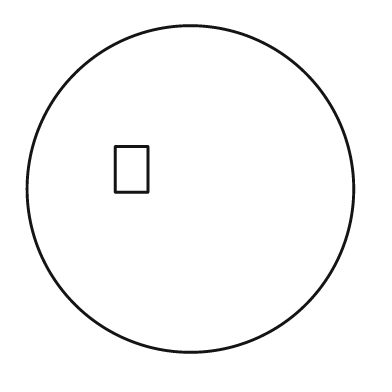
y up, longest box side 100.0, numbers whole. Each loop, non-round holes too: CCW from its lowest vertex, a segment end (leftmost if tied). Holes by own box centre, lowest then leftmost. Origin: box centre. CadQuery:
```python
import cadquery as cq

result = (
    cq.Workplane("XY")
    .moveTo(0.0, 0.0)
    .circle(50.0)
    .moveTo(-23.0, -1.0)
    .lineTo(-13.0, -1.0)
    .lineTo(-13.0, 13.0)
    .lineTo(-23.0, 13.0)
    .close()
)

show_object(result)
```